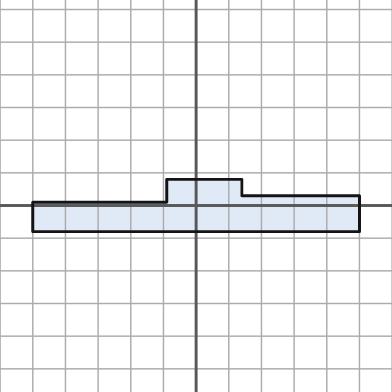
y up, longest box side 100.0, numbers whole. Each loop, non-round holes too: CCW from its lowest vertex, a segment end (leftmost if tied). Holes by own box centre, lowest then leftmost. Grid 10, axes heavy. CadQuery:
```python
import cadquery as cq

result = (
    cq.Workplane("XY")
    .moveTo(-50.0, -8.0)
    .lineTo(50.0, -8.0)
    .lineTo(50.0, 3.0)
    .lineTo(14.0, 3.0)
    .lineTo(14.0, 8.0)
    .lineTo(-9.0, 8.0)
    .lineTo(-9.0, 1.0)
    .lineTo(-50.0, 1.0)
    .close()
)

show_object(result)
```